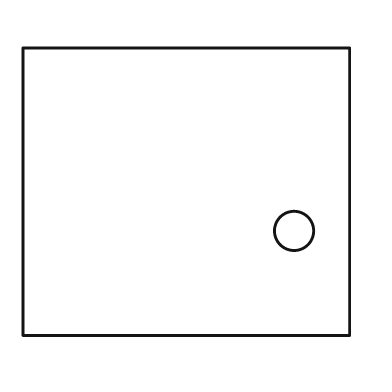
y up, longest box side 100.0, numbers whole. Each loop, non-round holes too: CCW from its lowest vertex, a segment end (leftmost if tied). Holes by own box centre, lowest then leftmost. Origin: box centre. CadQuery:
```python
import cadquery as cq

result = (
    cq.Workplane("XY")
    .moveTo(-50.0, -44.0)
    .lineTo(50.0, -44.0)
    .lineTo(50.0, 44.0)
    .lineTo(-50.0, 44.0)
    .close()
    .moveTo(33.0, -12.0)
    .circle(6.0)
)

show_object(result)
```